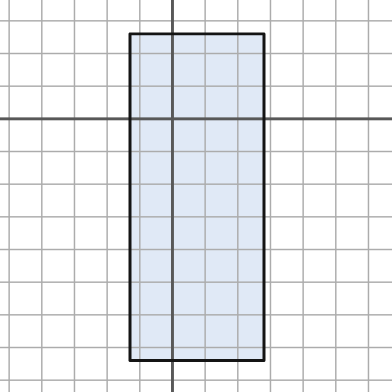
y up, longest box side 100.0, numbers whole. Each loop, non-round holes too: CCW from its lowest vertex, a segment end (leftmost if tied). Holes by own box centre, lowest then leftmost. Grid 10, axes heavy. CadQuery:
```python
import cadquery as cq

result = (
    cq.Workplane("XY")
    .moveTo(-13.0, -74.0)
    .lineTo(28.0, -74.0)
    .lineTo(28.0, 26.0)
    .lineTo(-13.0, 26.0)
    .close()
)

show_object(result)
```